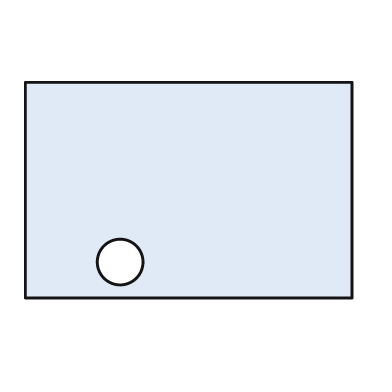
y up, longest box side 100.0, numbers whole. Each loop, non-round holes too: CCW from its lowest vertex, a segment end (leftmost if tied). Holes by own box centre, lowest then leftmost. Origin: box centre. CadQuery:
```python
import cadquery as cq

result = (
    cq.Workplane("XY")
    .moveTo(-50.0, -33.0)
    .lineTo(50.0, -33.0)
    .lineTo(50.0, 33.0)
    .lineTo(-50.0, 33.0)
    .close()
    .moveTo(-21.0, -22.0)
    .circle(7.0)
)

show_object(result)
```